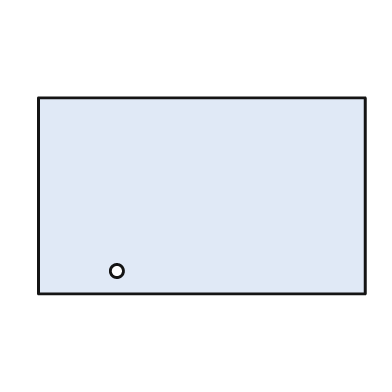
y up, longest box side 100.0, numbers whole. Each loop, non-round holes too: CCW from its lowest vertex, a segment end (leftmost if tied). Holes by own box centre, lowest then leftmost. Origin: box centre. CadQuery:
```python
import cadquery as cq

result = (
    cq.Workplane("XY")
    .moveTo(-50.0, -30.0)
    .lineTo(50.0, -30.0)
    .lineTo(50.0, 30.0)
    .lineTo(-50.0, 30.0)
    .close()
    .moveTo(-26.0, -23.0)
    .circle(2.0)
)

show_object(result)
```